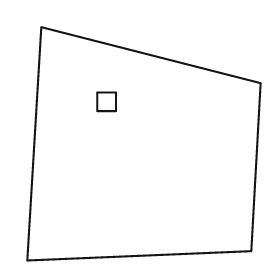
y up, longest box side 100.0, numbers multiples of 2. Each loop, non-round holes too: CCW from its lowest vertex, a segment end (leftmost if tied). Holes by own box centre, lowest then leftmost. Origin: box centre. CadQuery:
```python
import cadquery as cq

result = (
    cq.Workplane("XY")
    .moveTo(-50.0, -50.0)
    .lineTo(46.0, -46.0)
    .lineTo(50.0, 26.0)
    .lineTo(-44.0, 50.0)
    .close()
    .moveTo(-20.0, 14.0)
    .lineTo(-12.0, 14.0)
    .lineTo(-12.0, 22.0)
    .lineTo(-20.0, 22.0)
    .close()
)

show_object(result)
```